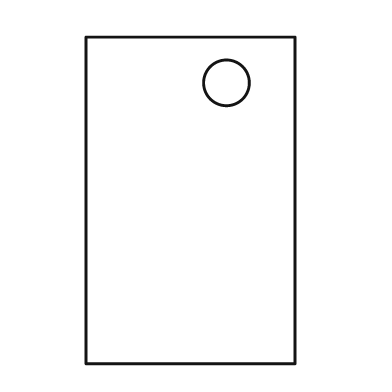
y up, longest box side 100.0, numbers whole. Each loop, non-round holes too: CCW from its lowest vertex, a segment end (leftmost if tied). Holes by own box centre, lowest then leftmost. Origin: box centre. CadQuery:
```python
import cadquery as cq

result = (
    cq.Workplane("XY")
    .moveTo(-32.0, -50.0)
    .lineTo(32.0, -50.0)
    .lineTo(32.0, 50.0)
    .lineTo(-32.0, 50.0)
    .close()
    .moveTo(11.0, 36.0)
    .circle(7.0)
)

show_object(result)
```